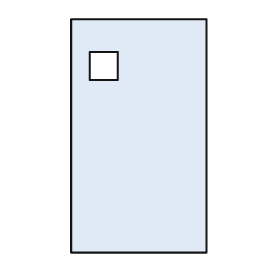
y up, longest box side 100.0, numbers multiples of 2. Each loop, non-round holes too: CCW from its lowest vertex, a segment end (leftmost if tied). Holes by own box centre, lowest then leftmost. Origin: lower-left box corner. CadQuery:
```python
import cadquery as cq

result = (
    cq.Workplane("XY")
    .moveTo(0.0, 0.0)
    .lineTo(58.0, 0.0)
    .lineTo(58.0, 100.0)
    .lineTo(0.0, 100.0)
    .close()
    .moveTo(8.0, 74.0)
    .lineTo(20.0, 74.0)
    .lineTo(20.0, 86.0)
    .lineTo(8.0, 86.0)
    .close()
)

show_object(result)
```